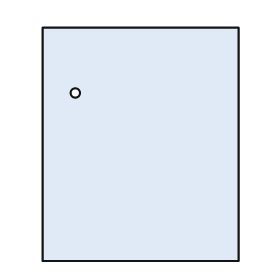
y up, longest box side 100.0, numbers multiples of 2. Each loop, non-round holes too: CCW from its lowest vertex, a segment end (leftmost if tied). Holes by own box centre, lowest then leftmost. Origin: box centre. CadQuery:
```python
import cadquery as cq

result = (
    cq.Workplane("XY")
    .moveTo(-42.0, -50.0)
    .lineTo(42.0, -50.0)
    .lineTo(42.0, 50.0)
    .lineTo(-42.0, 50.0)
    .close()
    .moveTo(-28.0, 22.0)
    .circle(2.0)
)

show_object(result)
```